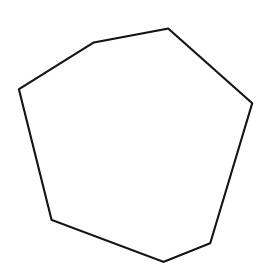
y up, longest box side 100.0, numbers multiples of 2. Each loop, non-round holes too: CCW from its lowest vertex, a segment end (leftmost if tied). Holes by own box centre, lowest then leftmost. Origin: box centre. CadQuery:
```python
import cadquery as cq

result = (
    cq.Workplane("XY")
    .moveTo(12.0, -50.0)
    .lineTo(32.0, -42.0)
    .lineTo(50.0, 18.0)
    .lineTo(14.0, 50.0)
    .lineTo(-18.0, 44.0)
    .lineTo(-50.0, 24.0)
    .lineTo(-36.0, -32.0)
    .close()
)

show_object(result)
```